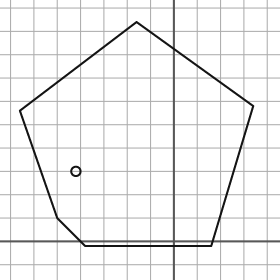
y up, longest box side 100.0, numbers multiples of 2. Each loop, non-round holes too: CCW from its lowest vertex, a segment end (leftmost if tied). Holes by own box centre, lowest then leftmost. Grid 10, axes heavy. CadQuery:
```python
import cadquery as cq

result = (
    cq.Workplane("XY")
    .moveTo(-38.0, -2.0)
    .lineTo(16.0, -2.0)
    .lineTo(34.0, 58.0)
    .lineTo(-16.0, 94.0)
    .lineTo(-66.0, 56.0)
    .lineTo(-50.0, 10.0)
    .close()
    .moveTo(-42.0, 30.0)
    .circle(2.0)
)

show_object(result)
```